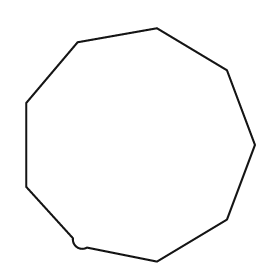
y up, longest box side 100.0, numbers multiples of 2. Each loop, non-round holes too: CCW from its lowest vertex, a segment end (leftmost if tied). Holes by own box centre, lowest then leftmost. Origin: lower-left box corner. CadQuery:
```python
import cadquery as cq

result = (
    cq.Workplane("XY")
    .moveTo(56.0, 0.0)
    .lineTo(86.0, 18.0)
    .lineTo(98.0, 50.0)
    .lineTo(86.0, 82.0)
    .lineTo(56.0, 100.0)
    .lineTo(22.0, 94.0)
    .lineTo(0.0, 68.0)
    .lineTo(0.0, 32.0)
    .lineTo(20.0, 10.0)
    .threePointArc((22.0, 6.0), (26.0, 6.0))
    .close()
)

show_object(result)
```